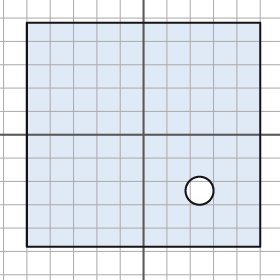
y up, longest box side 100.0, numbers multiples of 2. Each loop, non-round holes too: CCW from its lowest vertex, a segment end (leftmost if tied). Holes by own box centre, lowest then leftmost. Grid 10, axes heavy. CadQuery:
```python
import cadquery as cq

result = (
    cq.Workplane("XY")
    .moveTo(-50.0, -48.0)
    .lineTo(50.0, -48.0)
    .lineTo(50.0, 48.0)
    .lineTo(-50.0, 48.0)
    .close()
    .moveTo(24.0, -24.0)
    .circle(6.0)
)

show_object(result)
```